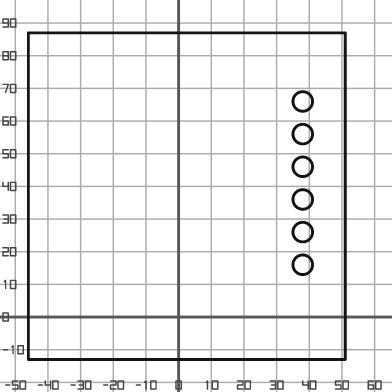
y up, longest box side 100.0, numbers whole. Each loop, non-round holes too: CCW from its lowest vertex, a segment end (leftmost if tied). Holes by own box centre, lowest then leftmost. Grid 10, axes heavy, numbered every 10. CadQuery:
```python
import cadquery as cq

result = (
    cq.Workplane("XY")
    .moveTo(-46.0, -13.0)
    .lineTo(51.0, -13.0)
    .lineTo(51.0, 87.0)
    .lineTo(-46.0, 87.0)
    .close()
    .moveTo(38.0, 16.0)
    .circle(3.0)
    .moveTo(38.0, 26.0)
    .circle(3.0)
    .moveTo(38.0, 36.0)
    .circle(3.0)
    .moveTo(38.0, 46.0)
    .circle(3.0)
    .moveTo(38.0, 56.0)
    .circle(3.0)
    .moveTo(38.0, 66.0)
    .circle(3.0)
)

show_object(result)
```